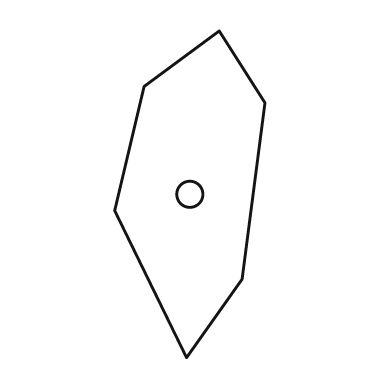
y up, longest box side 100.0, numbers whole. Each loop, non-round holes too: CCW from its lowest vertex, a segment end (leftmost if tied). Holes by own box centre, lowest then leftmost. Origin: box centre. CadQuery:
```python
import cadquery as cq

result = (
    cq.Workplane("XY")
    .moveTo(-1.0, -50.0)
    .lineTo(16.0, -26.0)
    .lineTo(23.0, 28.0)
    .lineTo(9.0, 50.0)
    .lineTo(-14.0, 33.0)
    .lineTo(-23.0, -5.0)
    .close()
    .moveTo(0.0, 0.0)
    .circle(4.0)
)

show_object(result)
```